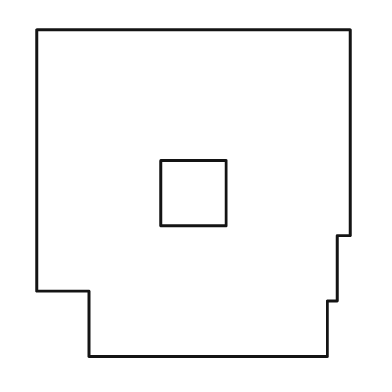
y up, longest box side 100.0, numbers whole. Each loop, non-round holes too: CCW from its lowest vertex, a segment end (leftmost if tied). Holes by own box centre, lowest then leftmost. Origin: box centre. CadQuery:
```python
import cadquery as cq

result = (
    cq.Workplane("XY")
    .moveTo(-32.0, -50.0)
    .lineTo(41.0, -50.0)
    .lineTo(41.0, -33.0)
    .lineTo(44.0, -33.0)
    .lineTo(44.0, -13.0)
    .lineTo(48.0, -13.0)
    .lineTo(48.0, 50.0)
    .lineTo(-48.0, 50.0)
    .lineTo(-48.0, -30.0)
    .lineTo(-32.0, -30.0)
    .close()
    .moveTo(-10.0, -10.0)
    .lineTo(10.0, -10.0)
    .lineTo(10.0, 10.0)
    .lineTo(-10.0, 10.0)
    .close()
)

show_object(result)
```